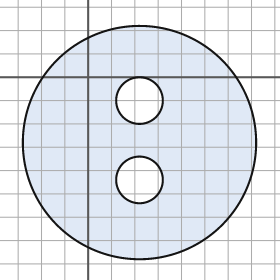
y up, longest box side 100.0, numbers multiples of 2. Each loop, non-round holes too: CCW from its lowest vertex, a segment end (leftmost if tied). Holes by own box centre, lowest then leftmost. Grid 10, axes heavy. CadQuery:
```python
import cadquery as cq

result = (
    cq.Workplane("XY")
    .moveTo(22.0, -28.0)
    .circle(50.0)
    .moveTo(22.0, -44.0)
    .circle(10.0)
    .moveTo(22.0, -10.0)
    .circle(10.0)
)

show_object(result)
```